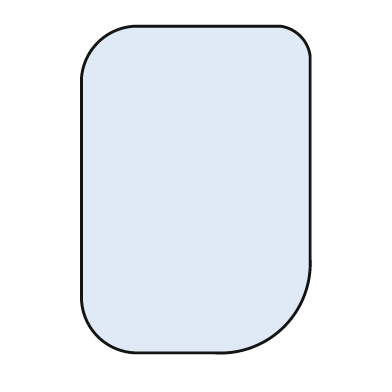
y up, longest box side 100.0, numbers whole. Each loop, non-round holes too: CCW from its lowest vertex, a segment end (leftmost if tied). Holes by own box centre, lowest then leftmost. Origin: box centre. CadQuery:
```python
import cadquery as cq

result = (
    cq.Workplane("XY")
    .moveTo(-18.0, -50.0)
    .lineTo(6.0, -50.0)
    .threePointArc((27.0, -42.0), (35.0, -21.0))
    .lineTo(35.0, 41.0)
    .threePointArc((32.0, 47.0), (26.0, 50.0))
    .lineTo(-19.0, 50.0)
    .threePointArc((-30.0, 45.0), (-35.0, 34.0))
    .lineTo(-35.0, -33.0)
    .threePointArc((-30.0, -45.0), (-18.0, -50.0))
    .close()
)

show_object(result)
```